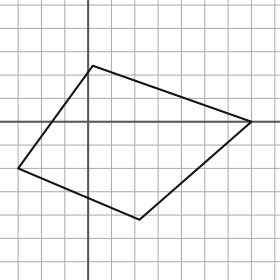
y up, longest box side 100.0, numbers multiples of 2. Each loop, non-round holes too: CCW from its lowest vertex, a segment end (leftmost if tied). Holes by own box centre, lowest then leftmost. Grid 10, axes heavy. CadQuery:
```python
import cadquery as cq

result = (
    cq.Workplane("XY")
    .moveTo(22.0, -42.0)
    .lineTo(70.0, 0.0)
    .lineTo(2.0, 24.0)
    .lineTo(-30.0, -20.0)
    .close()
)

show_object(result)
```